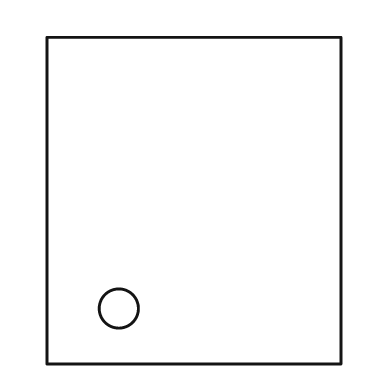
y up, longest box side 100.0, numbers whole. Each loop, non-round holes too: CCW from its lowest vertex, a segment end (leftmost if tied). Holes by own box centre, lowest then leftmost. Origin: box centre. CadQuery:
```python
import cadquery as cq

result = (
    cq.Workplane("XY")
    .moveTo(-45.0, -50.0)
    .lineTo(45.0, -50.0)
    .lineTo(45.0, 50.0)
    .lineTo(-45.0, 50.0)
    .close()
    .moveTo(-23.0, -33.0)
    .circle(6.0)
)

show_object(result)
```